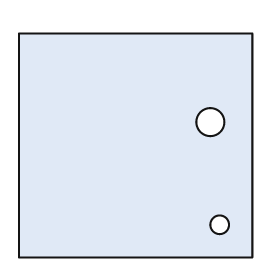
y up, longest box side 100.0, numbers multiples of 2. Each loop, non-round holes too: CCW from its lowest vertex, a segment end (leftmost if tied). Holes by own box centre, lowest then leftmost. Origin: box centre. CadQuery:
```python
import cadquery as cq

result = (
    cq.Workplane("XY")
    .moveTo(-50.0, -48.0)
    .lineTo(50.0, -48.0)
    .lineTo(50.0, 48.0)
    .lineTo(-50.0, 48.0)
    .close()
    .moveTo(36.0, -34.0)
    .circle(4.0)
    .moveTo(32.0, 10.0)
    .circle(6.0)
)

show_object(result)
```